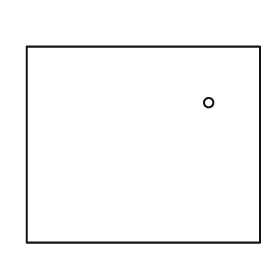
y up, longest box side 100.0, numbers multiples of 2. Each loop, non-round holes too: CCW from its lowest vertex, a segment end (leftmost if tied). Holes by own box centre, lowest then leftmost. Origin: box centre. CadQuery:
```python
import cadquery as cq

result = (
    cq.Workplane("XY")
    .moveTo(-50.0, -42.0)
    .lineTo(50.0, -42.0)
    .lineTo(50.0, 42.0)
    .lineTo(-50.0, 42.0)
    .close()
    .moveTo(28.0, 18.0)
    .circle(2.0)
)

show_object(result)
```